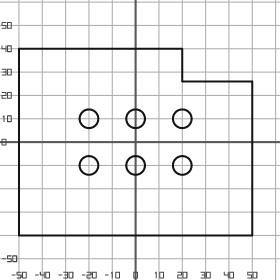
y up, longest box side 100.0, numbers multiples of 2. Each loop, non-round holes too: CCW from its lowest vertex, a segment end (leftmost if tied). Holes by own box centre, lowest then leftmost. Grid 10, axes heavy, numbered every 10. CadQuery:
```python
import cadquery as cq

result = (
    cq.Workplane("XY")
    .moveTo(-50.0, -40.0)
    .lineTo(50.0, -40.0)
    .lineTo(50.0, 26.0)
    .lineTo(20.0, 26.0)
    .lineTo(20.0, 40.0)
    .lineTo(-50.0, 40.0)
    .close()
    .moveTo(-20.0, -10.0)
    .circle(4.0)
    .moveTo(0.0, -10.0)
    .circle(4.0)
    .moveTo(20.0, -10.0)
    .circle(4.0)
    .moveTo(-20.0, 10.0)
    .circle(4.0)
    .moveTo(0.0, 10.0)
    .circle(4.0)
    .moveTo(20.0, 10.0)
    .circle(4.0)
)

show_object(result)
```